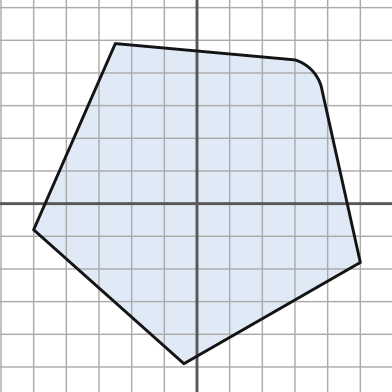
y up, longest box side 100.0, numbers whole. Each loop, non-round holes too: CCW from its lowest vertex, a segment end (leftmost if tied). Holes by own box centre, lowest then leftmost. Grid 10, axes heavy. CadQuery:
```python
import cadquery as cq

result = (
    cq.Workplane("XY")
    .moveTo(-4.0, -49.0)
    .lineTo(50.0, -18.0)
    .lineTo(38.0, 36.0)
    .threePointArc((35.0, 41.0), (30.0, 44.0))
    .lineTo(-25.0, 49.0)
    .lineTo(-50.0, -8.0)
    .close()
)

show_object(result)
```